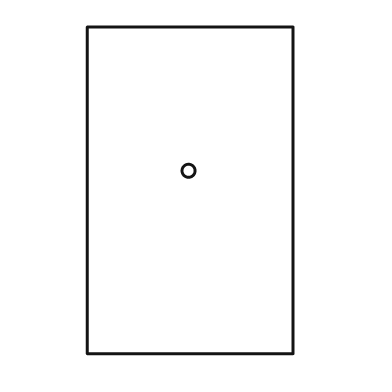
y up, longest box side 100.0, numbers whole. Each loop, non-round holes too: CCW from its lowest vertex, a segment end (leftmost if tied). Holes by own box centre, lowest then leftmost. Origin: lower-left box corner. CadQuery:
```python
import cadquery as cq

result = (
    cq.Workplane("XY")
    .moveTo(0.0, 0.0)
    .lineTo(63.0, 0.0)
    .lineTo(63.0, 100.0)
    .lineTo(0.0, 100.0)
    .close()
    .moveTo(31.0, 56.0)
    .circle(2.0)
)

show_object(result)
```